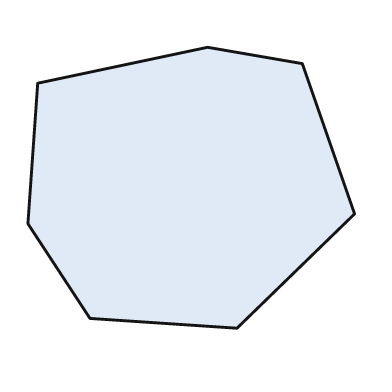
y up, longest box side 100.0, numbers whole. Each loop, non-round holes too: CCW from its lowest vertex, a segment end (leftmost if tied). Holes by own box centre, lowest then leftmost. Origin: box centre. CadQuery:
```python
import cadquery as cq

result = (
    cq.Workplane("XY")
    .moveTo(14.0, -43.0)
    .lineTo(50.0, -8.0)
    .lineTo(34.0, 38.0)
    .lineTo(5.0, 43.0)
    .lineTo(-47.0, 32.0)
    .lineTo(-50.0, -11.0)
    .lineTo(-31.0, -40.0)
    .close()
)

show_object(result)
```